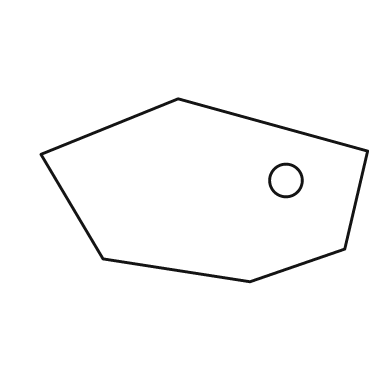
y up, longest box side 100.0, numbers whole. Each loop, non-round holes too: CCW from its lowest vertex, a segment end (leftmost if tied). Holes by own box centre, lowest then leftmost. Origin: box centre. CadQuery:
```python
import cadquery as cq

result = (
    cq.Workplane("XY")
    .moveTo(14.0, -28.0)
    .lineTo(43.0, -18.0)
    .lineTo(50.0, 12.0)
    .lineTo(-8.0, 28.0)
    .lineTo(-50.0, 11.0)
    .lineTo(-31.0, -21.0)
    .close()
    .moveTo(25.0, 3.0)
    .circle(5.0)
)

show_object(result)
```